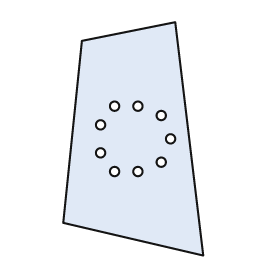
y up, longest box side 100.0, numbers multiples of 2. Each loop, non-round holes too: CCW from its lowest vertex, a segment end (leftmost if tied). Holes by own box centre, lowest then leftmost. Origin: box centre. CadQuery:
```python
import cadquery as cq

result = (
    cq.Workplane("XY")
    .moveTo(30.0, -50.0)
    .lineTo(18.0, 50.0)
    .lineTo(-22.0, 42.0)
    .lineTo(-30.0, -36.0)
    .close()
    .moveTo(-8.0, -14.0)
    .circle(2.0)
    .moveTo(2.0, -14.0)
    .circle(2.0)
    .moveTo(12.0, -10.0)
    .circle(2.0)
    .moveTo(-14.0, -6.0)
    .circle(2.0)
    .moveTo(16.0, 0.0)
    .circle(2.0)
    .moveTo(-14.0, 6.0)
    .circle(2.0)
    .moveTo(12.0, 10.0)
    .circle(2.0)
    .moveTo(-8.0, 14.0)
    .circle(2.0)
    .moveTo(2.0, 14.0)
    .circle(2.0)
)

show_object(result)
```